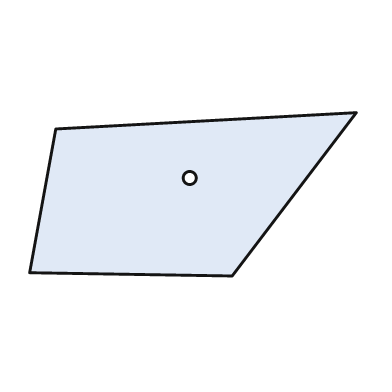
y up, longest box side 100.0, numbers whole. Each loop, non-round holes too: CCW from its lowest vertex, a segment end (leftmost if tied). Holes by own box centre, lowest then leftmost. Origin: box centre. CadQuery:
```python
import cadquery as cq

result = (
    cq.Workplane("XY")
    .moveTo(12.0, -25.0)
    .lineTo(50.0, 25.0)
    .lineTo(-42.0, 20.0)
    .lineTo(-50.0, -24.0)
    .close()
    .moveTo(-1.0, 5.0)
    .circle(2.0)
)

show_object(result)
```